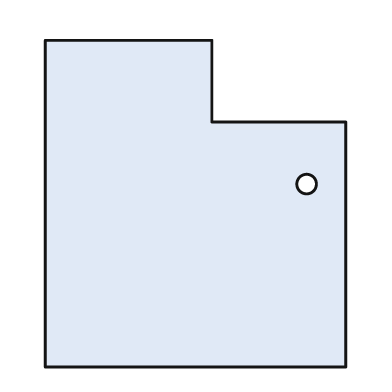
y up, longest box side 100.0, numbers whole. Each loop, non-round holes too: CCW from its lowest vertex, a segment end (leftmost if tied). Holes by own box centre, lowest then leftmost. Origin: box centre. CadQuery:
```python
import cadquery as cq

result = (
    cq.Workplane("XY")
    .moveTo(-46.0, -50.0)
    .lineTo(46.0, -50.0)
    .lineTo(46.0, 25.0)
    .lineTo(5.0, 25.0)
    .lineTo(5.0, 50.0)
    .lineTo(-46.0, 50.0)
    .close()
    .moveTo(34.0, 6.0)
    .circle(3.0)
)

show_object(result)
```